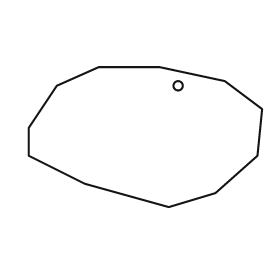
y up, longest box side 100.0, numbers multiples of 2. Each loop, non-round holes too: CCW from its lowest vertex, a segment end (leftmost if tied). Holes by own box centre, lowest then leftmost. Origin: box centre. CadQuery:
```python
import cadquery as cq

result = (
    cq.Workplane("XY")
    .moveTo(10.0, -30.0)
    .lineTo(30.0, -24.0)
    .lineTo(48.0, -8.0)
    .lineTo(50.0, 12.0)
    .lineTo(34.0, 24.0)
    .lineTo(6.0, 30.0)
    .lineTo(-20.0, 30.0)
    .lineTo(-38.0, 22.0)
    .lineTo(-50.0, 4.0)
    .lineTo(-50.0, -8.0)
    .lineTo(-26.0, -20.0)
    .close()
    .moveTo(14.0, 22.0)
    .circle(2.0)
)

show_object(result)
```